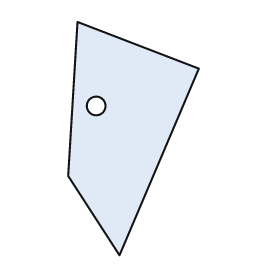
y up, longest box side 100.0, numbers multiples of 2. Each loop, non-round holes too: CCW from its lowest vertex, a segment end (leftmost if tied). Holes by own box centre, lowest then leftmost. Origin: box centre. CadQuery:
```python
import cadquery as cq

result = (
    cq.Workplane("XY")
    .moveTo(-6.0, -50.0)
    .lineTo(28.0, 30.0)
    .lineTo(-24.0, 50.0)
    .lineTo(-28.0, -16.0)
    .close()
    .moveTo(-16.0, 14.0)
    .circle(4.0)
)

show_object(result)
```